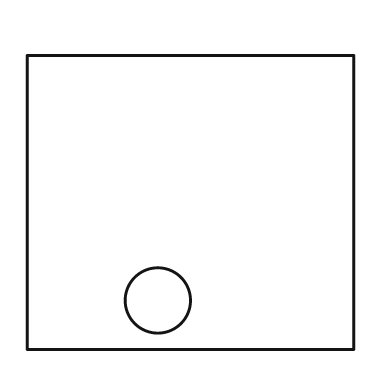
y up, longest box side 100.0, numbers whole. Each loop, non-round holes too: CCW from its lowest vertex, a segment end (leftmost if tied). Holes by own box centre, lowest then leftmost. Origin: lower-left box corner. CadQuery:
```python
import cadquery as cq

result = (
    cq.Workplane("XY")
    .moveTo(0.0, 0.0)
    .lineTo(100.0, 0.0)
    .lineTo(100.0, 90.0)
    .lineTo(0.0, 90.0)
    .close()
    .moveTo(40.0, 15.0)
    .circle(10.0)
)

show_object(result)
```